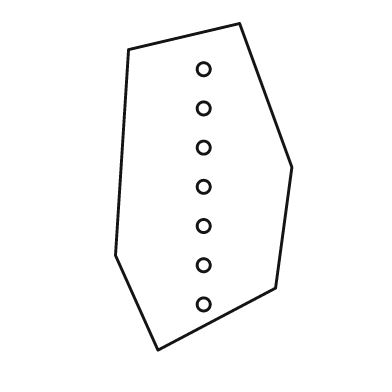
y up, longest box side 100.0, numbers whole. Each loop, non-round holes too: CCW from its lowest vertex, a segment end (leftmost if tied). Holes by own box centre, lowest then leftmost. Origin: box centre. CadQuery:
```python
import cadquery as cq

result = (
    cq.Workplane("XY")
    .moveTo(-14.0, -50.0)
    .lineTo(22.0, -31.0)
    .lineTo(27.0, 6.0)
    .lineTo(11.0, 50.0)
    .lineTo(-23.0, 42.0)
    .lineTo(-27.0, -21.0)
    .close()
    .moveTo(0.0, -36.0)
    .circle(2.0)
    .moveTo(0.0, -24.0)
    .circle(2.0)
    .moveTo(0.0, -12.0)
    .circle(2.0)
    .moveTo(0.0, 0.0)
    .circle(2.0)
    .moveTo(0.0, 12.0)
    .circle(2.0)
    .moveTo(0.0, 24.0)
    .circle(2.0)
    .moveTo(0.0, 36.0)
    .circle(2.0)
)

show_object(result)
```